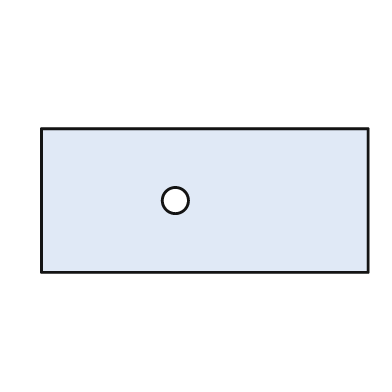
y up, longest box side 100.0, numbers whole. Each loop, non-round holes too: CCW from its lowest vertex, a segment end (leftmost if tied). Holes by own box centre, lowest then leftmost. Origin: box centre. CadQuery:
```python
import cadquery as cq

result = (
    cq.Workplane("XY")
    .moveTo(-50.0, -22.0)
    .lineTo(50.0, -22.0)
    .lineTo(50.0, 22.0)
    .lineTo(-50.0, 22.0)
    .close()
    .moveTo(-9.0, 0.0)
    .circle(4.0)
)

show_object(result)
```